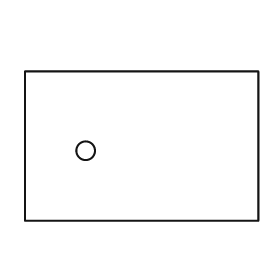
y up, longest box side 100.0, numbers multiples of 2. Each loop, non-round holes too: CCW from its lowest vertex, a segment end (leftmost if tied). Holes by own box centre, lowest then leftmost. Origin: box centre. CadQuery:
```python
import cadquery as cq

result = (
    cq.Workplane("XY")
    .moveTo(-50.0, -32.0)
    .lineTo(50.0, -32.0)
    .lineTo(50.0, 32.0)
    .lineTo(-50.0, 32.0)
    .close()
    .moveTo(-24.0, -2.0)
    .circle(4.0)
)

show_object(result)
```